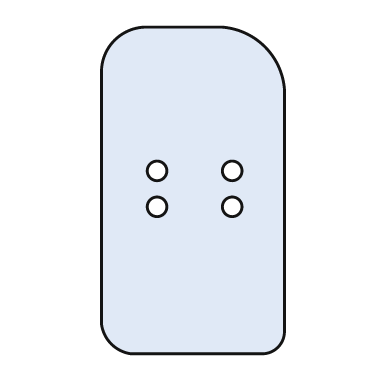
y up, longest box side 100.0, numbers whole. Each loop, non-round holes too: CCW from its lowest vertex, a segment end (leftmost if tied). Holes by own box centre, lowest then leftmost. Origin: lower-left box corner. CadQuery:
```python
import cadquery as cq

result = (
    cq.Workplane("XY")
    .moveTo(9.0, 0.0)
    .lineTo(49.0, 0.0)
    .threePointArc((54.0, 2.0), (56.0, 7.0))
    .lineTo(56.0, 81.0)
    .threePointArc((50.0, 94.0), (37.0, 100.0))
    .lineTo(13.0, 100.0)
    .threePointArc((4.0, 96.0), (0.0, 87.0))
    .lineTo(0.0, 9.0)
    .threePointArc((3.0, 3.0), (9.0, 0.0))
    .close()
    .moveTo(17.0, 45.0)
    .circle(3.0)
    .moveTo(40.0, 45.0)
    .circle(3.0)
    .moveTo(17.0, 56.0)
    .circle(3.0)
    .moveTo(40.0, 56.0)
    .circle(3.0)
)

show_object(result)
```